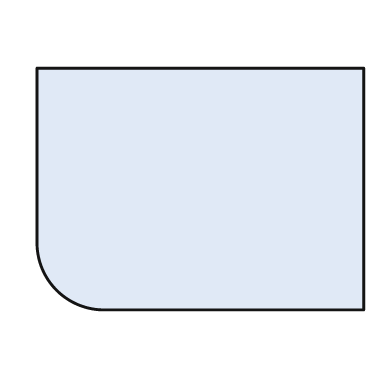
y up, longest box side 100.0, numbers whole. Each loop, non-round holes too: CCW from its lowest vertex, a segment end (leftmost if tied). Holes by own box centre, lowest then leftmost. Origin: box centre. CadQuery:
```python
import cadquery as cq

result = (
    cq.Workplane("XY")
    .moveTo(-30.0, -37.0)
    .lineTo(50.0, -37.0)
    .lineTo(50.0, 37.0)
    .lineTo(-50.0, 37.0)
    .lineTo(-50.0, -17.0)
    .threePointArc((-44.0, -31.0), (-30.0, -37.0))
    .close()
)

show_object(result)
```